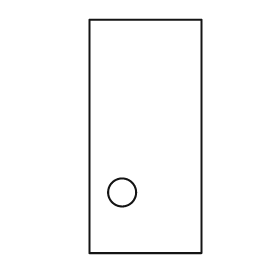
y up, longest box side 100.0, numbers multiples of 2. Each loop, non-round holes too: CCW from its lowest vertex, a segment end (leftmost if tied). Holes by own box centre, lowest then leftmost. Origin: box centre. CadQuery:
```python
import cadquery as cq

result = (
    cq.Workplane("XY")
    .moveTo(-24.0, -50.0)
    .lineTo(24.0, -50.0)
    .lineTo(24.0, 50.0)
    .lineTo(-24.0, 50.0)
    .close()
    .moveTo(-10.0, -24.0)
    .circle(6.0)
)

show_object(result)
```